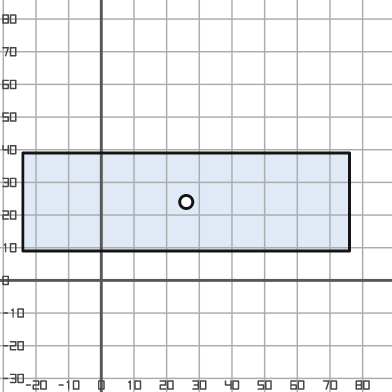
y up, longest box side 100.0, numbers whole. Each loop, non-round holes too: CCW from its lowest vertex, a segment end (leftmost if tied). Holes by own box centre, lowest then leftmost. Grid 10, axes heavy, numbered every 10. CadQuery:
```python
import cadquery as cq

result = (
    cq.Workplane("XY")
    .moveTo(-24.0, 9.0)
    .lineTo(76.0, 9.0)
    .lineTo(76.0, 39.0)
    .lineTo(-24.0, 39.0)
    .close()
    .moveTo(26.0, 24.0)
    .circle(2.0)
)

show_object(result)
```